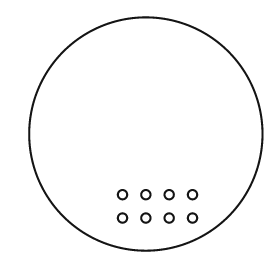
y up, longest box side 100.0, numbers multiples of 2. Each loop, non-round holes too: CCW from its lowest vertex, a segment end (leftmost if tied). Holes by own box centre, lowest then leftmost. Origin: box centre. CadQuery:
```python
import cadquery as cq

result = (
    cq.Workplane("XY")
    .moveTo(0.0, 0.0)
    .circle(50.0)
    .moveTo(-10.0, -36.0)
    .circle(2.0)
    .moveTo(0.0, -36.0)
    .circle(2.0)
    .moveTo(10.0, -36.0)
    .circle(2.0)
    .moveTo(20.0, -36.0)
    .circle(2.0)
    .moveTo(-10.0, -26.0)
    .circle(2.0)
    .moveTo(0.0, -26.0)
    .circle(2.0)
    .moveTo(10.0, -26.0)
    .circle(2.0)
    .moveTo(20.0, -26.0)
    .circle(2.0)
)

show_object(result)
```